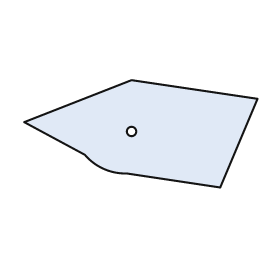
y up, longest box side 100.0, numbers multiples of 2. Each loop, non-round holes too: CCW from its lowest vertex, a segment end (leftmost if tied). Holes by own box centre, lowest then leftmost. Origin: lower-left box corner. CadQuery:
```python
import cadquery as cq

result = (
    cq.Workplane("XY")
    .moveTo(84.0, 0.0)
    .lineTo(100.0, 38.0)
    .lineTo(46.0, 46.0)
    .lineTo(0.0, 28.0)
    .lineTo(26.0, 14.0)
    .threePointArc((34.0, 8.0), (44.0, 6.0))
    .close()
    .moveTo(46.0, 24.0)
    .circle(2.0)
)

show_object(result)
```